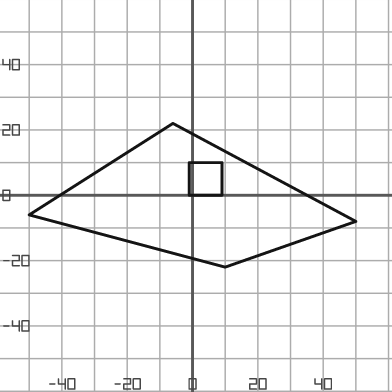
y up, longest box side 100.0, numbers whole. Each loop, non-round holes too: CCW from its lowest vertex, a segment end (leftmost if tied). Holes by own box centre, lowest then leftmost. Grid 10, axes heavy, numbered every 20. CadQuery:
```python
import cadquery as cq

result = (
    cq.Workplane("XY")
    .moveTo(10.0, -22.0)
    .lineTo(50.0, -8.0)
    .lineTo(-6.0, 22.0)
    .lineTo(-50.0, -6.0)
    .close()
    .moveTo(-1.0, 0.0)
    .lineTo(9.0, 0.0)
    .lineTo(9.0, 10.0)
    .lineTo(-1.0, 10.0)
    .close()
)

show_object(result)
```